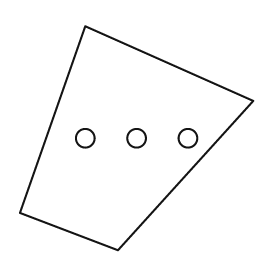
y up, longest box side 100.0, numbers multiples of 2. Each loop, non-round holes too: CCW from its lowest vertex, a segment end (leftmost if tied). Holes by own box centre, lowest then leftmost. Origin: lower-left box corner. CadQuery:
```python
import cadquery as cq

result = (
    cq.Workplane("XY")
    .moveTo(42.0, 0.0)
    .lineTo(100.0, 64.0)
    .lineTo(28.0, 96.0)
    .lineTo(0.0, 16.0)
    .close()
    .moveTo(28.0, 48.0)
    .circle(4.0)
    .moveTo(50.0, 48.0)
    .circle(4.0)
    .moveTo(72.0, 48.0)
    .circle(4.0)
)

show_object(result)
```